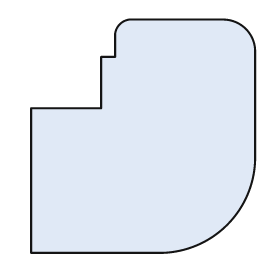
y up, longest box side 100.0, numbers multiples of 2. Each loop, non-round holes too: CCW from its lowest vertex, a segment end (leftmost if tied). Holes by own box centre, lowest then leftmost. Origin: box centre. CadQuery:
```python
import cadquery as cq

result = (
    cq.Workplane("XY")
    .moveTo(-48.0, -50.0)
    .lineTo(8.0, -50.0)
    .threePointArc((36.0, -38.0), (48.0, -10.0))
    .lineTo(48.0, 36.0)
    .threePointArc((44.0, 46.0), (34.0, 50.0))
    .lineTo(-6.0, 50.0)
    .threePointArc((-10.0, 48.0), (-12.0, 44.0))
    .lineTo(-12.0, 34.0)
    .lineTo(-18.0, 34.0)
    .lineTo(-18.0, 12.0)
    .lineTo(-48.0, 12.0)
    .close()
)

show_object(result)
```